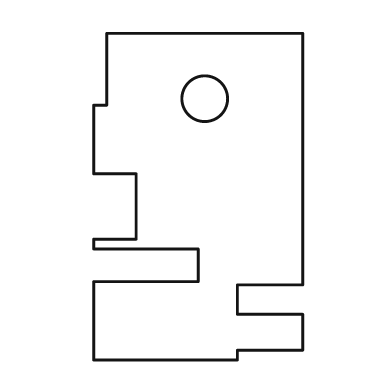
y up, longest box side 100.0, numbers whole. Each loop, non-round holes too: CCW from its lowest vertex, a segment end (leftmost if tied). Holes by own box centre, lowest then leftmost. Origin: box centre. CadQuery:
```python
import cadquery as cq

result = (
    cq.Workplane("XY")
    .moveTo(-32.0, -50.0)
    .lineTo(12.0, -50.0)
    .lineTo(12.0, -47.0)
    .lineTo(32.0, -47.0)
    .lineTo(32.0, -36.0)
    .lineTo(12.0, -36.0)
    .lineTo(12.0, -27.0)
    .lineTo(32.0, -27.0)
    .lineTo(32.0, 50.0)
    .lineTo(-28.0, 50.0)
    .lineTo(-28.0, 28.0)
    .lineTo(-32.0, 28.0)
    .lineTo(-32.0, 7.0)
    .lineTo(-19.0, 7.0)
    .lineTo(-19.0, -13.0)
    .lineTo(-32.0, -13.0)
    .lineTo(-32.0, -16.0)
    .lineTo(0.0, -16.0)
    .lineTo(0.0, -26.0)
    .lineTo(-32.0, -26.0)
    .close()
    .moveTo(2.0, 30.0)
    .circle(7.0)
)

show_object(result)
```